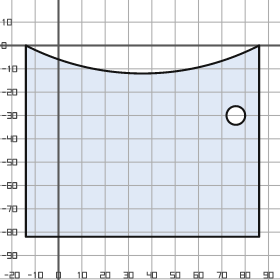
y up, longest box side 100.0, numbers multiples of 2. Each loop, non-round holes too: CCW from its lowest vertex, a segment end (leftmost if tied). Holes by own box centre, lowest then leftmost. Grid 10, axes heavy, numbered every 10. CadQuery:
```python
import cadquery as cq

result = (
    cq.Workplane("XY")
    .moveTo(-14.0, -82.0)
    .lineTo(86.0, -82.0)
    .lineTo(86.0, 0.0)
    .threePointArc((36.0, -12.0), (-14.0, 0.0))
    .close()
    .moveTo(76.0, -30.0)
    .circle(4.0)
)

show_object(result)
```